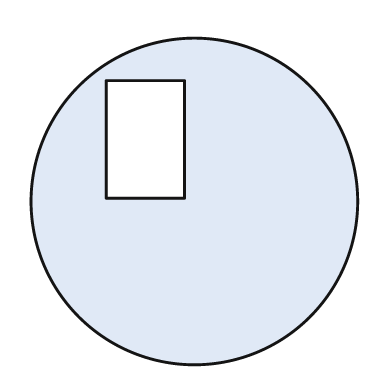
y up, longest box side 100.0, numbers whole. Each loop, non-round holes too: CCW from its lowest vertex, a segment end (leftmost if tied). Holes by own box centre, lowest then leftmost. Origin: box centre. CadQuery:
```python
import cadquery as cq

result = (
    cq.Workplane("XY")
    .moveTo(0.0, 0.0)
    .circle(50.0)
    .moveTo(-27.0, 1.0)
    .lineTo(-3.0, 1.0)
    .lineTo(-3.0, 37.0)
    .lineTo(-27.0, 37.0)
    .close()
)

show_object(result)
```